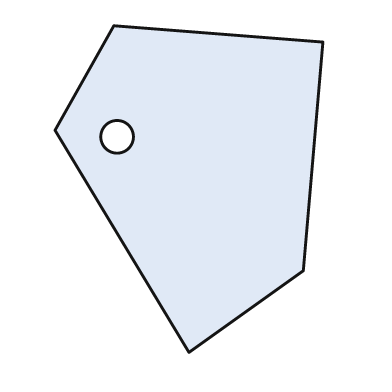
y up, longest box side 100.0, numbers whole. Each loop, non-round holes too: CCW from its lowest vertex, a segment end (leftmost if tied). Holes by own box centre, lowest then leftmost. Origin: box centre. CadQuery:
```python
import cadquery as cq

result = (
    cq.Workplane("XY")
    .moveTo(0.0, -50.0)
    .lineTo(35.0, -25.0)
    .lineTo(41.0, 45.0)
    .lineTo(-23.0, 50.0)
    .lineTo(-41.0, 18.0)
    .close()
    .moveTo(-22.0, 16.0)
    .circle(5.0)
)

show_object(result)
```